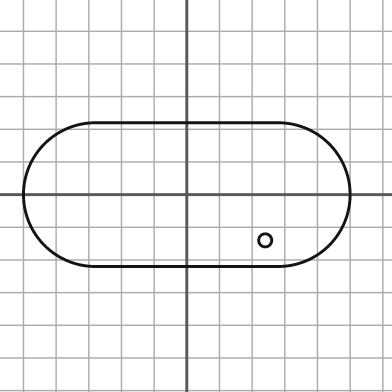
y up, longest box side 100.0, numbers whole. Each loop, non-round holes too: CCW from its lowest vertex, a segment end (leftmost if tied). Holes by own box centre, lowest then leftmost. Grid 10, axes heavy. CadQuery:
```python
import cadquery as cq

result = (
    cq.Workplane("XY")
    .moveTo(-28.0, -22.0)
    .lineTo(28.0, -22.0)
    .threePointArc((50.0, 0.0), (28.0, 22.0))
    .lineTo(-28.0, 22.0)
    .threePointArc((-50.0, 0.0), (-28.0, -22.0))
    .close()
    .moveTo(24.0, -14.0)
    .circle(2.0)
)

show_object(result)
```